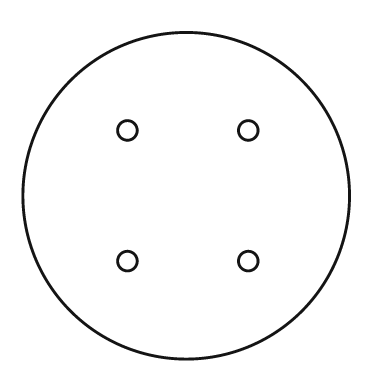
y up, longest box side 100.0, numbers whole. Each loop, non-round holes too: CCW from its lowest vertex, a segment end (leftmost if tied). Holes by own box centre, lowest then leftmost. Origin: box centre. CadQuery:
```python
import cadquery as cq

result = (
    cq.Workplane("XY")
    .moveTo(0.0, 0.0)
    .circle(50.0)
    .moveTo(-18.0, -20.0)
    .circle(3.0)
    .moveTo(19.0, -20.0)
    .circle(3.0)
    .moveTo(-18.0, 20.0)
    .circle(3.0)
    .moveTo(19.0, 20.0)
    .circle(3.0)
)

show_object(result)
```